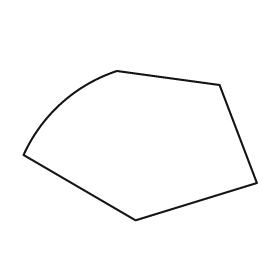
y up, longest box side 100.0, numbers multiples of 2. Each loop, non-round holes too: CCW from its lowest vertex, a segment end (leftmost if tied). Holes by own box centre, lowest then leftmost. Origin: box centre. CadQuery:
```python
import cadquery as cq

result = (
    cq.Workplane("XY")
    .moveTo(-2.0, -32.0)
    .lineTo(50.0, -16.0)
    .lineTo(34.0, 26.0)
    .lineTo(-10.0, 32.0)
    .threePointArc((-34.0, 18.0), (-50.0, -4.0))
    .close()
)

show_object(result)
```